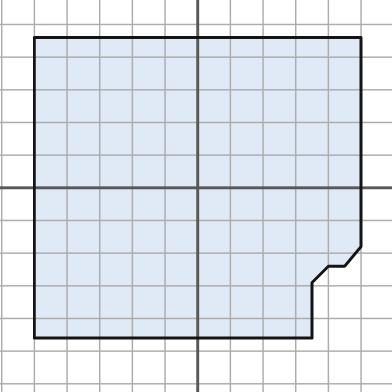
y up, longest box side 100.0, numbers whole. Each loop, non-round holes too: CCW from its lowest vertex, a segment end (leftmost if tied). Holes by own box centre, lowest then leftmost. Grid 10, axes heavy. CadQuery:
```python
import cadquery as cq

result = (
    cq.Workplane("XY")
    .moveTo(-50.0, -46.0)
    .lineTo(35.0, -46.0)
    .lineTo(35.0, -29.0)
    .lineTo(40.0, -24.0)
    .lineTo(45.0, -24.0)
    .lineTo(50.0, -18.0)
    .lineTo(50.0, 46.0)
    .lineTo(-50.0, 46.0)
    .close()
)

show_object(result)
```